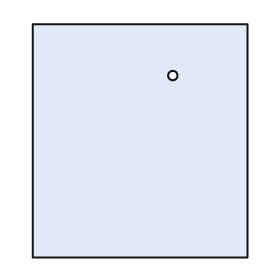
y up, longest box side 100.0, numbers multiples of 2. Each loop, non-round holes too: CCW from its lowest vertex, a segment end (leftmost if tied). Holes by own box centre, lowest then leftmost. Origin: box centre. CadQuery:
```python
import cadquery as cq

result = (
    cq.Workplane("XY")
    .moveTo(-46.0, -50.0)
    .lineTo(46.0, -50.0)
    .lineTo(46.0, 50.0)
    .lineTo(-46.0, 50.0)
    .close()
    .moveTo(14.0, 28.0)
    .circle(2.0)
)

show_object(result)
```